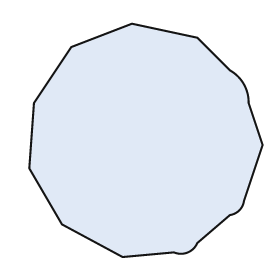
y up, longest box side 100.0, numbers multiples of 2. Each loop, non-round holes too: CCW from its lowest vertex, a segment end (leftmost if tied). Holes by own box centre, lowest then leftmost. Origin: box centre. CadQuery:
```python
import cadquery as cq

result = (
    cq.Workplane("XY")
    .moveTo(-10.0, -50.0)
    .lineTo(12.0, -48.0)
    .threePointArc((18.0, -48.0), (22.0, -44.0))
    .lineTo(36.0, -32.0)
    .threePointArc((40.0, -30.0), (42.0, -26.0))
    .lineTo(50.0, -2.0)
    .lineTo(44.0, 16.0)
    .threePointArc((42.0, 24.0), (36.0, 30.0))
    .lineTo(22.0, 44.0)
    .lineTo(-6.0, 50.0)
    .lineTo(-32.0, 40.0)
    .lineTo(-48.0, 16.0)
    .lineTo(-50.0, -12.0)
    .lineTo(-36.0, -36.0)
    .close()
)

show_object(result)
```